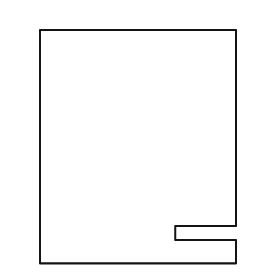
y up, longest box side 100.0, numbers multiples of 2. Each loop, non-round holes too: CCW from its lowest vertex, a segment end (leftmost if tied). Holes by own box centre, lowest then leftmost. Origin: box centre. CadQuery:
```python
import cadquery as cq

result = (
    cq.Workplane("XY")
    .moveTo(-42.0, -50.0)
    .lineTo(42.0, -50.0)
    .lineTo(42.0, -40.0)
    .lineTo(16.0, -40.0)
    .lineTo(16.0, -34.0)
    .lineTo(42.0, -34.0)
    .lineTo(42.0, 50.0)
    .lineTo(-42.0, 50.0)
    .close()
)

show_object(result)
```